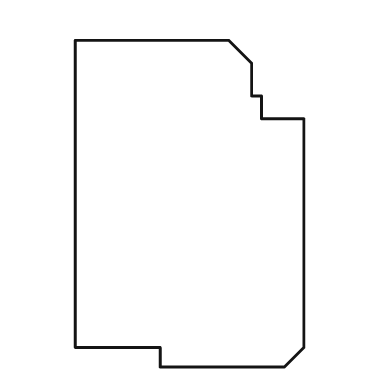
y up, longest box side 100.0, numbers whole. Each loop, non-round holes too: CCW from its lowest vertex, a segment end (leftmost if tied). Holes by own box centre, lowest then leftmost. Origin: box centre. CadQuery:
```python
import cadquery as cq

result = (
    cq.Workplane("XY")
    .moveTo(-9.0, -50.0)
    .lineTo(29.0, -50.0)
    .lineTo(35.0, -44.0)
    .lineTo(35.0, 26.0)
    .lineTo(22.0, 26.0)
    .lineTo(22.0, 33.0)
    .lineTo(19.0, 33.0)
    .lineTo(19.0, 43.0)
    .lineTo(12.0, 50.0)
    .lineTo(-35.0, 50.0)
    .lineTo(-35.0, -44.0)
    .lineTo(-9.0, -44.0)
    .close()
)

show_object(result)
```